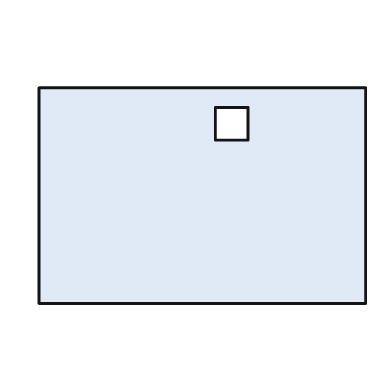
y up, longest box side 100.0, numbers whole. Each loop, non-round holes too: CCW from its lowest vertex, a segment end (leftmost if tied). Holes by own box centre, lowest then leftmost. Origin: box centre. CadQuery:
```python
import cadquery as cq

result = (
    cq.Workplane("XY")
    .moveTo(-50.0, -33.0)
    .lineTo(50.0, -33.0)
    .lineTo(50.0, 33.0)
    .lineTo(-50.0, 33.0)
    .close()
    .moveTo(4.0, 17.0)
    .lineTo(14.0, 17.0)
    .lineTo(14.0, 27.0)
    .lineTo(4.0, 27.0)
    .close()
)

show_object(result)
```